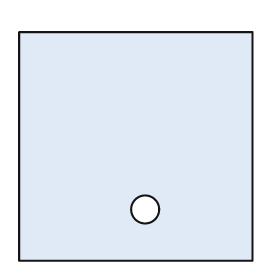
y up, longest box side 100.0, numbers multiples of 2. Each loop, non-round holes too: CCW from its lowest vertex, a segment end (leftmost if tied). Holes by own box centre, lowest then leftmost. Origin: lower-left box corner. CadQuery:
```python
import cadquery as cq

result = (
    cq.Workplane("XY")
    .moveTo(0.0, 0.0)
    .lineTo(100.0, 0.0)
    .lineTo(100.0, 98.0)
    .lineTo(0.0, 98.0)
    .close()
    .moveTo(54.0, 22.0)
    .circle(6.0)
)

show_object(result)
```